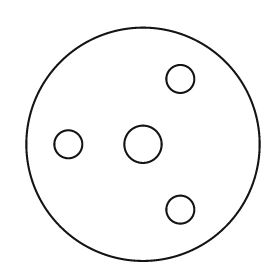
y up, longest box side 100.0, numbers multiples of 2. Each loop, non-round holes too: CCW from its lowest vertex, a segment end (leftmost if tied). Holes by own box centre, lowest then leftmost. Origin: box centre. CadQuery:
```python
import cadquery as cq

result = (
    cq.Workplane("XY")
    .moveTo(0.0, 0.0)
    .circle(50.0)
    .moveTo(16.0, -28.0)
    .circle(6.0)
    .moveTo(-32.0, 0.0)
    .circle(6.0)
    .moveTo(0.0, 0.0)
    .circle(8.0)
    .moveTo(16.0, 28.0)
    .circle(6.0)
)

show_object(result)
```